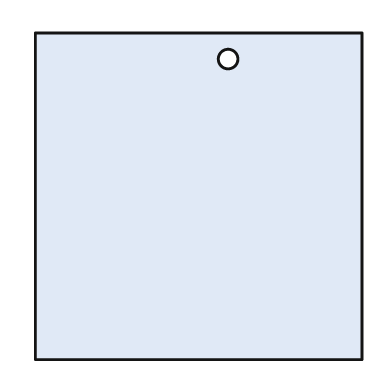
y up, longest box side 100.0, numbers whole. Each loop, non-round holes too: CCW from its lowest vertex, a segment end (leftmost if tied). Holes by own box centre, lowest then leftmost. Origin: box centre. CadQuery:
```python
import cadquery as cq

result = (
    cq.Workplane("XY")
    .moveTo(-50.0, -50.0)
    .lineTo(50.0, -50.0)
    .lineTo(50.0, 50.0)
    .lineTo(-50.0, 50.0)
    .close()
    .moveTo(9.0, 42.0)
    .circle(3.0)
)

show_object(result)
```